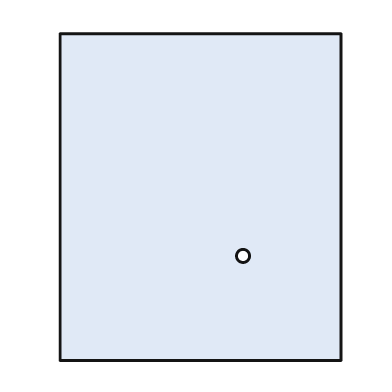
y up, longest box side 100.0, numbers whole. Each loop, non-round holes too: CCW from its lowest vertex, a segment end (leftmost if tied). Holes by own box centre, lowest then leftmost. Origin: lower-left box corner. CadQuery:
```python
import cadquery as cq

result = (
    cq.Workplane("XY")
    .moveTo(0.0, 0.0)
    .lineTo(86.0, 0.0)
    .lineTo(86.0, 100.0)
    .lineTo(0.0, 100.0)
    .close()
    .moveTo(56.0, 32.0)
    .circle(2.0)
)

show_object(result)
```